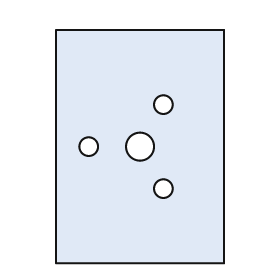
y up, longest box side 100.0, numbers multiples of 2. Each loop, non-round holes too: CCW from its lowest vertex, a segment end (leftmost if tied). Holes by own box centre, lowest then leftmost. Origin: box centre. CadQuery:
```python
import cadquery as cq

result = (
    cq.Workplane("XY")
    .moveTo(-36.0, -50.0)
    .lineTo(36.0, -50.0)
    .lineTo(36.0, 50.0)
    .lineTo(-36.0, 50.0)
    .close()
    .moveTo(10.0, -18.0)
    .circle(4.0)
    .moveTo(-22.0, 0.0)
    .circle(4.0)
    .moveTo(0.0, 0.0)
    .circle(6.0)
    .moveTo(10.0, 18.0)
    .circle(4.0)
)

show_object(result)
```